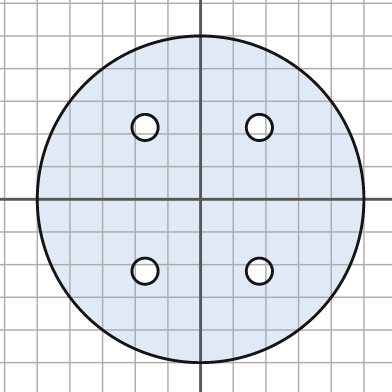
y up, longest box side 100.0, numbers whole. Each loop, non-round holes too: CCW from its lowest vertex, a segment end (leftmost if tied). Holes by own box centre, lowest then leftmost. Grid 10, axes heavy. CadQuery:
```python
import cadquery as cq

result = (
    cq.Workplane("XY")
    .moveTo(0.0, 0.0)
    .circle(50.0)
    .moveTo(-17.0, -22.0)
    .circle(4.0)
    .moveTo(18.0, -22.0)
    .circle(4.0)
    .moveTo(-17.0, 22.0)
    .circle(4.0)
    .moveTo(18.0, 22.0)
    .circle(4.0)
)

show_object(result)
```